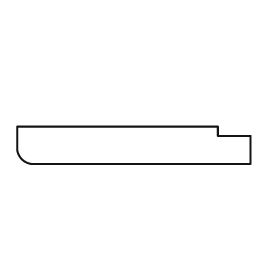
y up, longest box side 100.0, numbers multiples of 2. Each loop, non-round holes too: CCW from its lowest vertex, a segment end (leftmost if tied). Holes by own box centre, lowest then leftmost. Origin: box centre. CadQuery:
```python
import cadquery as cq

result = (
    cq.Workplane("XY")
    .moveTo(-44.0, -8.0)
    .lineTo(50.0, -8.0)
    .lineTo(50.0, 4.0)
    .lineTo(36.0, 4.0)
    .lineTo(36.0, 8.0)
    .lineTo(-50.0, 8.0)
    .lineTo(-50.0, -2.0)
    .threePointArc((-48.0, -6.0), (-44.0, -8.0))
    .close()
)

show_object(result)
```